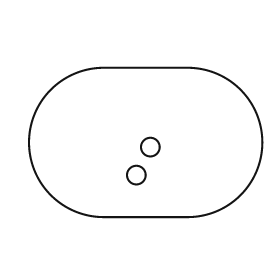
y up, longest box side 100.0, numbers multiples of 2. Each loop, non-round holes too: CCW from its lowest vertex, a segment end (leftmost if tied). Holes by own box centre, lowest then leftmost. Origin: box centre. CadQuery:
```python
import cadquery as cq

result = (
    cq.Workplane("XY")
    .moveTo(-18.0, -32.0)
    .lineTo(18.0, -32.0)
    .threePointArc((50.0, 0.0), (18.0, 32.0))
    .lineTo(-18.0, 32.0)
    .threePointArc((-50.0, 0.0), (-18.0, -32.0))
    .close()
    .moveTo(-4.0, -14.0)
    .circle(4.0)
    .moveTo(2.0, -2.0)
    .circle(4.0)
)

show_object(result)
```